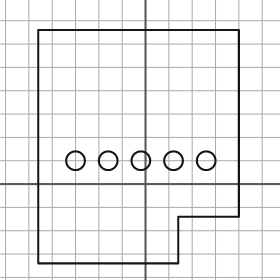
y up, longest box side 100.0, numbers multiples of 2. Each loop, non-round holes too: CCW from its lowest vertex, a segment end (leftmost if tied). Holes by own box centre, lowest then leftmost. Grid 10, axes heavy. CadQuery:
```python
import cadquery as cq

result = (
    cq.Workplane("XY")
    .moveTo(-46.0, -34.0)
    .lineTo(14.0, -34.0)
    .lineTo(14.0, -14.0)
    .lineTo(40.0, -14.0)
    .lineTo(40.0, 66.0)
    .lineTo(-46.0, 66.0)
    .close()
    .moveTo(-30.0, 10.0)
    .circle(4.0)
    .moveTo(-16.0, 10.0)
    .circle(4.0)
    .moveTo(-2.0, 10.0)
    .circle(4.0)
    .moveTo(12.0, 10.0)
    .circle(4.0)
    .moveTo(26.0, 10.0)
    .circle(4.0)
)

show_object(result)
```